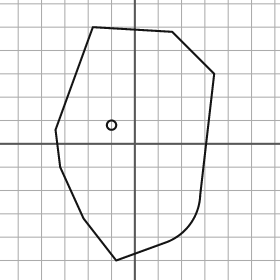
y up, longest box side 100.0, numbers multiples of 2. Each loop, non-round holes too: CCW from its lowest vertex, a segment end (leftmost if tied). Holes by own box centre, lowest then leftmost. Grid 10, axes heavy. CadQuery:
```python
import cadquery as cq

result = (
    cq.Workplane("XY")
    .moveTo(-8.0, -50.0)
    .lineTo(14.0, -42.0)
    .threePointArc((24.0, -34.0), (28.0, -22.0))
    .lineTo(34.0, 30.0)
    .lineTo(16.0, 48.0)
    .lineTo(-18.0, 50.0)
    .lineTo(-34.0, 6.0)
    .lineTo(-32.0, -10.0)
    .lineTo(-22.0, -32.0)
    .close()
    .moveTo(-10.0, 8.0)
    .circle(2.0)
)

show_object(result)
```